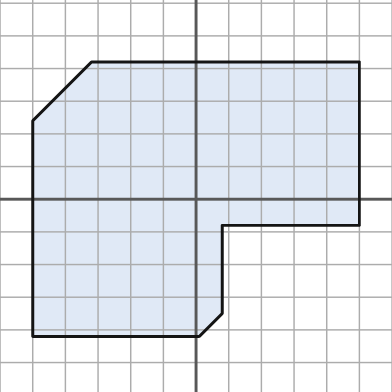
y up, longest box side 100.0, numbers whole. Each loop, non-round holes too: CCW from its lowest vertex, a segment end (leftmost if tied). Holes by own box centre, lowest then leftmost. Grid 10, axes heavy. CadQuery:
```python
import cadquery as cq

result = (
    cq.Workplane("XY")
    .moveTo(-50.0, -42.0)
    .lineTo(1.0, -42.0)
    .lineTo(8.0, -35.0)
    .lineTo(8.0, -8.0)
    .lineTo(50.0, -8.0)
    .lineTo(50.0, 42.0)
    .lineTo(-32.0, 42.0)
    .lineTo(-50.0, 24.0)
    .close()
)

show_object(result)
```